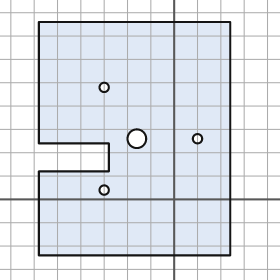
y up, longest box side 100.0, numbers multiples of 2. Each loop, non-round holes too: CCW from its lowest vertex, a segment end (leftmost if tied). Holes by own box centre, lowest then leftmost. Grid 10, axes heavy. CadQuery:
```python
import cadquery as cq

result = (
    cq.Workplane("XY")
    .moveTo(-58.0, -24.0)
    .lineTo(24.0, -24.0)
    .lineTo(24.0, 76.0)
    .lineTo(-58.0, 76.0)
    .lineTo(-58.0, 24.0)
    .lineTo(-28.0, 24.0)
    .lineTo(-28.0, 12.0)
    .lineTo(-58.0, 12.0)
    .close()
    .moveTo(-30.0, 4.0)
    .circle(2.0)
    .moveTo(-16.0, 26.0)
    .circle(4.0)
    .moveTo(10.0, 26.0)
    .circle(2.0)
    .moveTo(-30.0, 48.0)
    .circle(2.0)
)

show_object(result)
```